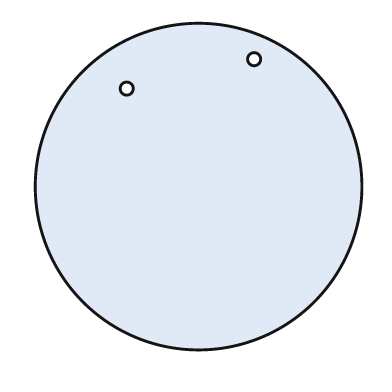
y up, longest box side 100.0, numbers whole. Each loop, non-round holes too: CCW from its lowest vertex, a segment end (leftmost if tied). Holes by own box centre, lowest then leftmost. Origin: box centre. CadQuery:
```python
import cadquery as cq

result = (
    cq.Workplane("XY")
    .moveTo(0.0, 0.0)
    .circle(50.0)
    .moveTo(-22.0, 30.0)
    .circle(2.0)
    .moveTo(17.0, 39.0)
    .circle(2.0)
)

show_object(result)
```